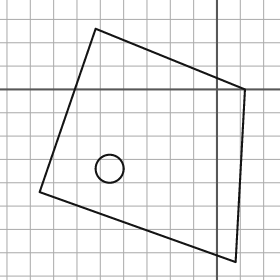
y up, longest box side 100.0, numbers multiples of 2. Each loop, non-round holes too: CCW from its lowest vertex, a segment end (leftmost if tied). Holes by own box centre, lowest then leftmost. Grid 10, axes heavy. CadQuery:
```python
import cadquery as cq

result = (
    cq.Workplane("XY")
    .moveTo(8.0, -74.0)
    .lineTo(12.0, 0.0)
    .lineTo(-52.0, 26.0)
    .lineTo(-76.0, -44.0)
    .close()
    .moveTo(-46.0, -34.0)
    .circle(6.0)
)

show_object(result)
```